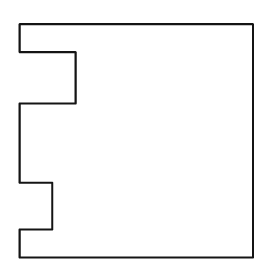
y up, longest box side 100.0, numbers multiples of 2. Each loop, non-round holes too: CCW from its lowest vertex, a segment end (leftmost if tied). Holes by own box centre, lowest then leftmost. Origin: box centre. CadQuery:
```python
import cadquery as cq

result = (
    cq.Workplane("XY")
    .moveTo(-50.0, -50.0)
    .lineTo(50.0, -50.0)
    .lineTo(50.0, 50.0)
    .lineTo(-50.0, 50.0)
    .lineTo(-50.0, 38.0)
    .lineTo(-26.0, 38.0)
    .lineTo(-26.0, 16.0)
    .lineTo(-50.0, 16.0)
    .lineTo(-50.0, -18.0)
    .lineTo(-36.0, -18.0)
    .lineTo(-36.0, -38.0)
    .lineTo(-50.0, -38.0)
    .close()
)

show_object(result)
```